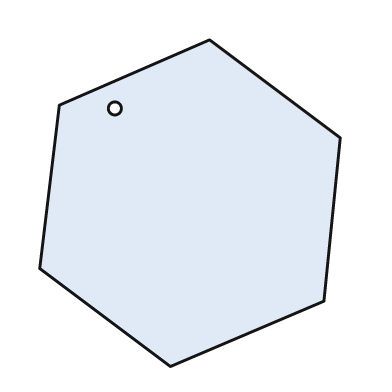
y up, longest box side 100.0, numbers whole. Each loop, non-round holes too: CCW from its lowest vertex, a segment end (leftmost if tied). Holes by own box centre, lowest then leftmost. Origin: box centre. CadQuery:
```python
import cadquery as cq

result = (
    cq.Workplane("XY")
    .moveTo(-6.0, -50.0)
    .lineTo(41.0, -30.0)
    .lineTo(46.0, 20.0)
    .lineTo(6.0, 50.0)
    .lineTo(-40.0, 30.0)
    .lineTo(-46.0, -20.0)
    .close()
    .moveTo(-23.0, 29.0)
    .circle(2.0)
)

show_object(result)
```